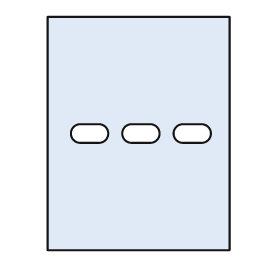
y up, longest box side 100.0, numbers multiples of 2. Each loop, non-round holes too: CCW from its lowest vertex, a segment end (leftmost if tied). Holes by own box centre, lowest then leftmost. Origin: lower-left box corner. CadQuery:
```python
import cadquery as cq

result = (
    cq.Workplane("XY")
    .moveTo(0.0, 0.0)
    .lineTo(78.0, 0.0)
    .lineTo(78.0, 100.0)
    .lineTo(0.0, 100.0)
    .close()
    .moveTo(14.0, 46.0)
    .lineTo(22.0, 46.0)
    .threePointArc((26.0, 50.0), (22.0, 54.0))
    .lineTo(14.0, 54.0)
    .threePointArc((10.0, 50.0), (14.0, 46.0))
    .close()
    .moveTo(36.0, 46.0)
    .lineTo(44.0, 46.0)
    .threePointArc((48.0, 50.0), (44.0, 54.0))
    .lineTo(36.0, 54.0)
    .threePointArc((32.0, 50.0), (36.0, 46.0))
    .close()
    .moveTo(58.0, 46.0)
    .lineTo(66.0, 46.0)
    .threePointArc((70.0, 50.0), (66.0, 54.0))
    .lineTo(58.0, 54.0)
    .threePointArc((54.0, 50.0), (58.0, 46.0))
    .close()
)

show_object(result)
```